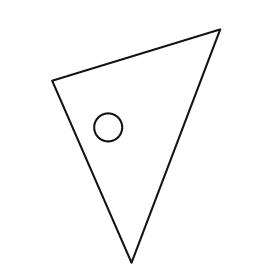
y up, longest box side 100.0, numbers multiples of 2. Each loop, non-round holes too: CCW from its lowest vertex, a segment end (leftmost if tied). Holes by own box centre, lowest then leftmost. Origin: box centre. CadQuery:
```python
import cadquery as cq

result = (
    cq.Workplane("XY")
    .moveTo(-2.0, -50.0)
    .lineTo(36.0, 50.0)
    .lineTo(-36.0, 28.0)
    .close()
    .moveTo(-12.0, 8.0)
    .circle(6.0)
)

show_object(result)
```